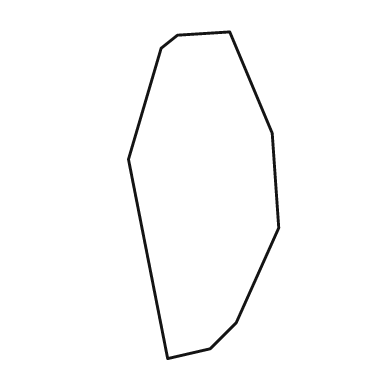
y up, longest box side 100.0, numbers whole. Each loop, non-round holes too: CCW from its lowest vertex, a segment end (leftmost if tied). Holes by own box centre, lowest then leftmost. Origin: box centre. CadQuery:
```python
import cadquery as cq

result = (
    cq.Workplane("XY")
    .moveTo(-11.0, -50.0)
    .lineTo(2.0, -47.0)
    .lineTo(10.0, -39.0)
    .lineTo(23.0, -10.0)
    .lineTo(21.0, 19.0)
    .lineTo(8.0, 50.0)
    .lineTo(-8.0, 49.0)
    .lineTo(-13.0, 45.0)
    .lineTo(-23.0, 11.0)
    .close()
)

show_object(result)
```